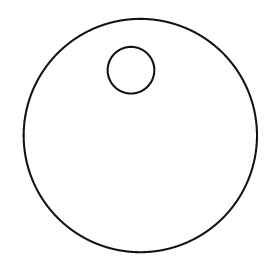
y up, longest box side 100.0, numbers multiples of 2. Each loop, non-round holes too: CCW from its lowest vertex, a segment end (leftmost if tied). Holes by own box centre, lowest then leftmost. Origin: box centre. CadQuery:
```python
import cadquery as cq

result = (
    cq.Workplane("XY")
    .moveTo(0.0, 0.0)
    .circle(50.0)
    .moveTo(-4.0, 28.0)
    .circle(10.0)
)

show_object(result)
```